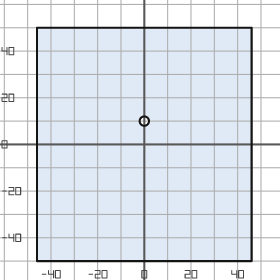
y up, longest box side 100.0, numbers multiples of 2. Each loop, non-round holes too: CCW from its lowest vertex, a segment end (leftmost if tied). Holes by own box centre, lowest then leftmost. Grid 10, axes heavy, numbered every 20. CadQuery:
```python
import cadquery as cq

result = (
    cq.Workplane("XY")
    .moveTo(-46.0, -50.0)
    .lineTo(46.0, -50.0)
    .lineTo(46.0, 50.0)
    .lineTo(-46.0, 50.0)
    .close()
    .moveTo(0.0, 10.0)
    .circle(2.0)
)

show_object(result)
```